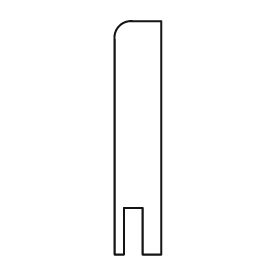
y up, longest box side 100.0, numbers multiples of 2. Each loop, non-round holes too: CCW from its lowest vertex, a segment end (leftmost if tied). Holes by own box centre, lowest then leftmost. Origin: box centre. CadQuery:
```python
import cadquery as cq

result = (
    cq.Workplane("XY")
    .moveTo(-10.0, -50.0)
    .lineTo(-6.0, -50.0)
    .lineTo(-6.0, -30.0)
    .lineTo(2.0, -30.0)
    .lineTo(2.0, -50.0)
    .lineTo(10.0, -50.0)
    .lineTo(10.0, 50.0)
    .lineTo(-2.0, 50.0)
    .threePointArc((-8.0, 48.0), (-10.0, 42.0))
    .close()
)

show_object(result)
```